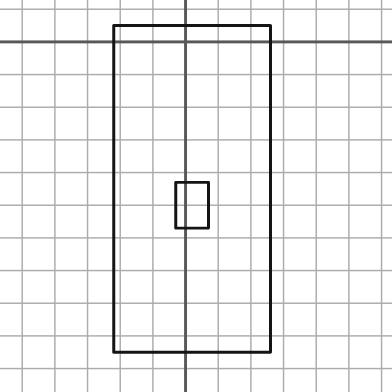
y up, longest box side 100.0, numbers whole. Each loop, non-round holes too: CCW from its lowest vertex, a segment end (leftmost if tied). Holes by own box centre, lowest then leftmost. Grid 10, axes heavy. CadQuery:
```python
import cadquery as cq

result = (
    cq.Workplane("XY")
    .moveTo(-22.0, -95.0)
    .lineTo(26.0, -95.0)
    .lineTo(26.0, 5.0)
    .lineTo(-22.0, 5.0)
    .close()
    .moveTo(-3.0, -57.0)
    .lineTo(7.0, -57.0)
    .lineTo(7.0, -43.0)
    .lineTo(-3.0, -43.0)
    .close()
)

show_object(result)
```